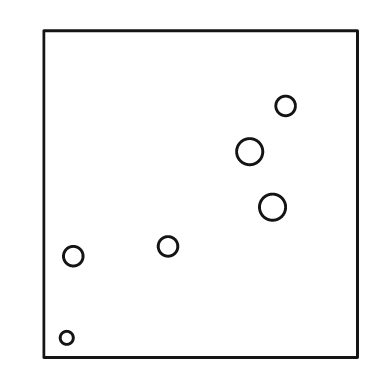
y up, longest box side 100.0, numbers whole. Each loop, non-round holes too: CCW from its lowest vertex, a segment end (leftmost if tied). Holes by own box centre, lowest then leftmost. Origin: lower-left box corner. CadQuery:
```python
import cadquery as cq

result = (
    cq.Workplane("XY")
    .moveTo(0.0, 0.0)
    .lineTo(96.0, 0.0)
    .lineTo(96.0, 100.0)
    .lineTo(0.0, 100.0)
    .close()
    .moveTo(7.0, 6.0)
    .circle(2.0)
    .moveTo(9.0, 31.0)
    .circle(3.0)
    .moveTo(38.0, 34.0)
    .circle(3.0)
    .moveTo(70.0, 46.0)
    .circle(4.0)
    .moveTo(63.0, 63.0)
    .circle(4.0)
    .moveTo(74.0, 77.0)
    .circle(3.0)
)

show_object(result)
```